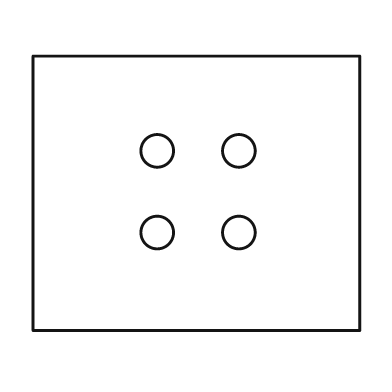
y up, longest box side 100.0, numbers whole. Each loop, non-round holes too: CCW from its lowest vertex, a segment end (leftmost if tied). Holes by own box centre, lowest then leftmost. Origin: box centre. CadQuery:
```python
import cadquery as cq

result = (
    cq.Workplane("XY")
    .moveTo(-50.0, -42.0)
    .lineTo(50.0, -42.0)
    .lineTo(50.0, 42.0)
    .lineTo(-50.0, 42.0)
    .close()
    .moveTo(-12.0, -12.0)
    .circle(5.0)
    .moveTo(13.0, -12.0)
    .circle(5.0)
    .moveTo(-12.0, 13.0)
    .circle(5.0)
    .moveTo(13.0, 13.0)
    .circle(5.0)
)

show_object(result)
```